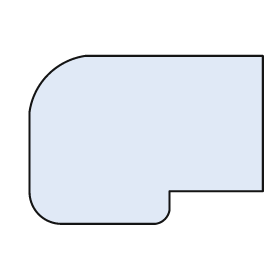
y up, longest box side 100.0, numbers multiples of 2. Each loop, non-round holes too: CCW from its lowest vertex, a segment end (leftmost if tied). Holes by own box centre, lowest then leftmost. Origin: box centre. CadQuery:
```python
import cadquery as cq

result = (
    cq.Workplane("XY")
    .moveTo(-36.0, -36.0)
    .lineTo(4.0, -36.0)
    .threePointArc((8.0, -34.0), (10.0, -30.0))
    .lineTo(10.0, -22.0)
    .lineTo(50.0, -22.0)
    .lineTo(50.0, 36.0)
    .lineTo(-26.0, 36.0)
    .threePointArc((-42.0, 28.0), (-50.0, 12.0))
    .lineTo(-50.0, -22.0)
    .threePointArc((-46.0, -32.0), (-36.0, -36.0))
    .close()
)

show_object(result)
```